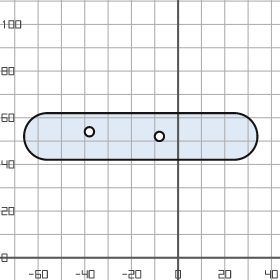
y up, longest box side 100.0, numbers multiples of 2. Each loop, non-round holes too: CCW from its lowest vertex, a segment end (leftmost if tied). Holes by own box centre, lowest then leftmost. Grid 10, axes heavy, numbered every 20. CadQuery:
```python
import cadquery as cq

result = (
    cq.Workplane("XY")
    .moveTo(-56.0, 42.0)
    .lineTo(24.0, 42.0)
    .threePointArc((34.0, 52.0), (24.0, 62.0))
    .lineTo(-56.0, 62.0)
    .threePointArc((-66.0, 52.0), (-56.0, 42.0))
    .close()
    .moveTo(-8.0, 52.0)
    .circle(2.0)
    .moveTo(-38.0, 54.0)
    .circle(2.0)
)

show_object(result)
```